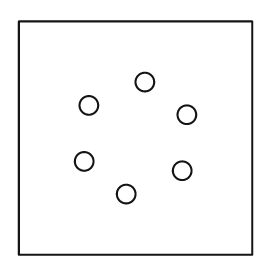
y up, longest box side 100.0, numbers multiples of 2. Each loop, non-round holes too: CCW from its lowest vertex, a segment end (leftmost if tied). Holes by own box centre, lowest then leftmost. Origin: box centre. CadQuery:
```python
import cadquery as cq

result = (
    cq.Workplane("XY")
    .moveTo(-50.0, -50.0)
    .lineTo(50.0, -50.0)
    .lineTo(50.0, 50.0)
    .lineTo(-50.0, 50.0)
    .close()
    .moveTo(-4.0, -24.0)
    .circle(4.0)
    .moveTo(20.0, -14.0)
    .circle(4.0)
    .moveTo(-22.0, -10.0)
    .circle(4.0)
    .moveTo(22.0, 10.0)
    .circle(4.0)
    .moveTo(-20.0, 14.0)
    .circle(4.0)
    .moveTo(4.0, 24.0)
    .circle(4.0)
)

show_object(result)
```